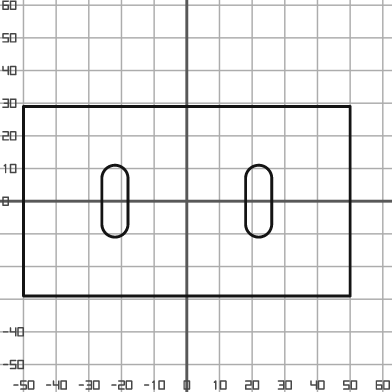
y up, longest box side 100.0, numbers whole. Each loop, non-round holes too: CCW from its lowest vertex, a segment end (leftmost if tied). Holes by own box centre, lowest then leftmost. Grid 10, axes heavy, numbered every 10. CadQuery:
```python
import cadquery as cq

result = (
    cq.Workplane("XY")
    .moveTo(-50.0, -29.0)
    .lineTo(50.0, -29.0)
    .lineTo(50.0, 29.0)
    .lineTo(-50.0, 29.0)
    .close()
    .moveTo(-26.0, -7.0)
    .threePointArc((-22.0, -11.0), (-18.0, -7.0))
    .lineTo(-18.0, 7.0)
    .threePointArc((-22.0, 11.0), (-26.0, 7.0))
    .close()
    .moveTo(18.0, -7.0)
    .threePointArc((22.0, -11.0), (26.0, -7.0))
    .lineTo(26.0, 7.0)
    .threePointArc((22.0, 11.0), (18.0, 7.0))
    .close()
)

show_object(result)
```